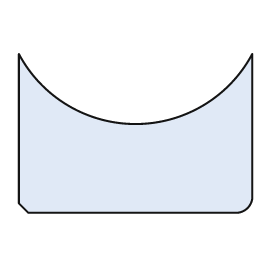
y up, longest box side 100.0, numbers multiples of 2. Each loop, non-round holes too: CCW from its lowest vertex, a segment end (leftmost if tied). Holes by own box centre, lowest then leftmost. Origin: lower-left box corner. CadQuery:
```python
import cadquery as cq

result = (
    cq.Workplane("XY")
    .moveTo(4.0, 0.0)
    .lineTo(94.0, 0.0)
    .threePointArc((98.0, 2.0), (100.0, 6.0))
    .lineTo(100.0, 68.0)
    .threePointArc((50.0, 38.0), (0.0, 68.0))
    .lineTo(0.0, 4.0)
    .close()
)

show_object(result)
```